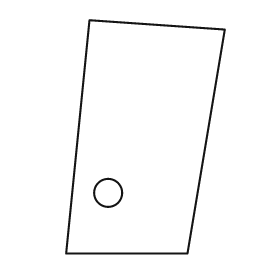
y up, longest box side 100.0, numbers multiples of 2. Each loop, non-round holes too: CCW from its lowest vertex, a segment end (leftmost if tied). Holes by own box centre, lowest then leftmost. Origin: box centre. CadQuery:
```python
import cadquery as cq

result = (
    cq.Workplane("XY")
    .moveTo(-34.0, -50.0)
    .lineTo(18.0, -50.0)
    .lineTo(34.0, 46.0)
    .lineTo(-24.0, 50.0)
    .close()
    .moveTo(-16.0, -24.0)
    .circle(6.0)
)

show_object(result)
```